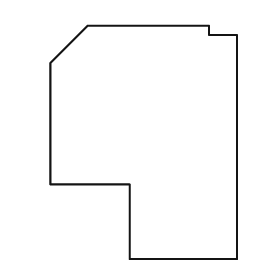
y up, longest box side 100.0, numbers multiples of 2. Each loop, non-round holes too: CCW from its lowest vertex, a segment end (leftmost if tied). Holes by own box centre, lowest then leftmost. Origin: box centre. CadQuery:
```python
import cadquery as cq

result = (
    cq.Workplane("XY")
    .moveTo(-6.0, -50.0)
    .lineTo(40.0, -50.0)
    .lineTo(40.0, 46.0)
    .lineTo(28.0, 46.0)
    .lineTo(28.0, 50.0)
    .lineTo(-24.0, 50.0)
    .lineTo(-40.0, 34.0)
    .lineTo(-40.0, -18.0)
    .lineTo(-6.0, -18.0)
    .close()
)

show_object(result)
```